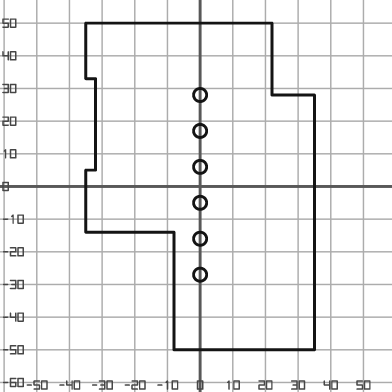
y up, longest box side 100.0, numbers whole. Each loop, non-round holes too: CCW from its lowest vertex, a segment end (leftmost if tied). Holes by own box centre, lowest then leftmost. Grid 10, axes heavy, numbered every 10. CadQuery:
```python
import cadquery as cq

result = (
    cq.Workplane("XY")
    .moveTo(-8.0, -50.0)
    .lineTo(35.0, -50.0)
    .lineTo(35.0, 28.0)
    .lineTo(22.0, 28.0)
    .lineTo(22.0, 50.0)
    .lineTo(-35.0, 50.0)
    .lineTo(-35.0, 33.0)
    .lineTo(-32.0, 33.0)
    .lineTo(-32.0, 5.0)
    .lineTo(-35.0, 5.0)
    .lineTo(-35.0, -14.0)
    .lineTo(-8.0, -14.0)
    .close()
    .moveTo(0.0, -27.0)
    .circle(2.0)
    .moveTo(0.0, -16.0)
    .circle(2.0)
    .moveTo(0.0, -5.0)
    .circle(2.0)
    .moveTo(0.0, 6.0)
    .circle(2.0)
    .moveTo(0.0, 17.0)
    .circle(2.0)
    .moveTo(0.0, 28.0)
    .circle(2.0)
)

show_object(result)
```